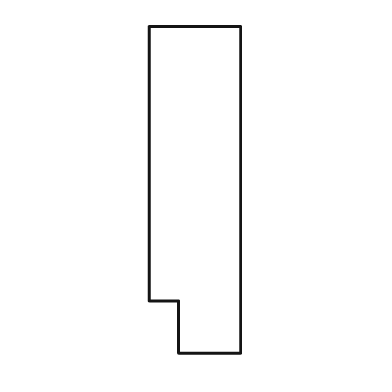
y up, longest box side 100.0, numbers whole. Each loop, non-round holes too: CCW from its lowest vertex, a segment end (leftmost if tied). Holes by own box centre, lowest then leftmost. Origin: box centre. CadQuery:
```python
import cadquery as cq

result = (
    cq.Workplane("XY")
    .moveTo(-5.0, -50.0)
    .lineTo(14.0, -50.0)
    .lineTo(14.0, 50.0)
    .lineTo(-14.0, 50.0)
    .lineTo(-14.0, -34.0)
    .lineTo(-5.0, -34.0)
    .close()
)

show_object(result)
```